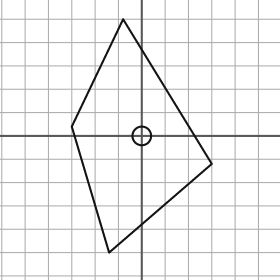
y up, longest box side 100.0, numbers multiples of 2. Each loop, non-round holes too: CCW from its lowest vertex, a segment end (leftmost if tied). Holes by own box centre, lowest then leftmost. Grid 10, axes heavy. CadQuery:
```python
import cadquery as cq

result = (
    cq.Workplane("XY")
    .moveTo(-14.0, -50.0)
    .lineTo(30.0, -12.0)
    .lineTo(-8.0, 50.0)
    .lineTo(-30.0, 4.0)
    .close()
    .moveTo(0.0, 0.0)
    .circle(4.0)
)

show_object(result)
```